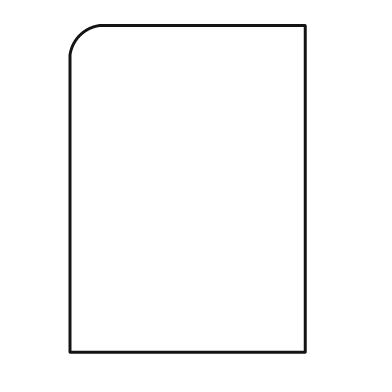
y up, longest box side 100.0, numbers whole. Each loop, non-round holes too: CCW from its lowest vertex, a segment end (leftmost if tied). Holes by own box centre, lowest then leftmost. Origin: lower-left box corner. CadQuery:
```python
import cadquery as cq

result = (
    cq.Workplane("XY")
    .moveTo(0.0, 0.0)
    .lineTo(72.0, 0.0)
    .lineTo(72.0, 100.0)
    .lineTo(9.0, 100.0)
    .threePointArc((3.0, 97.0), (0.0, 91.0))
    .close()
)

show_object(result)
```